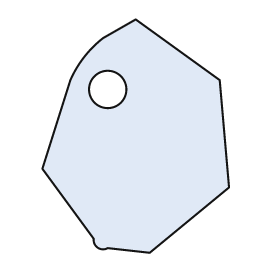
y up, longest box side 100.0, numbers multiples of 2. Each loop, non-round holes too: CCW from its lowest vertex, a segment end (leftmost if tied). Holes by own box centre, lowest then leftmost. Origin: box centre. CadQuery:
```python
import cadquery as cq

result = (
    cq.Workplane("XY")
    .moveTo(6.0, -50.0)
    .lineTo(40.0, -22.0)
    .lineTo(36.0, 24.0)
    .lineTo(0.0, 50.0)
    .lineTo(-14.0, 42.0)
    .threePointArc((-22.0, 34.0), (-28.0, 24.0))
    .lineTo(-40.0, -14.0)
    .lineTo(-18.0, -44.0)
    .threePointArc((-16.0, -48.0), (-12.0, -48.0))
    .close()
    .moveTo(-12.0, 20.0)
    .circle(8.0)
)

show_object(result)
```